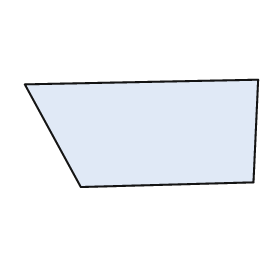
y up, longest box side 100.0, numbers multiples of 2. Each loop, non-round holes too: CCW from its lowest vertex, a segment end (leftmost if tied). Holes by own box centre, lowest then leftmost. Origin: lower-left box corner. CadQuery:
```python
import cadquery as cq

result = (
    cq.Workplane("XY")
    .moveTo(24.0, 0.0)
    .lineTo(98.0, 2.0)
    .lineTo(100.0, 46.0)
    .lineTo(0.0, 44.0)
    .close()
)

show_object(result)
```